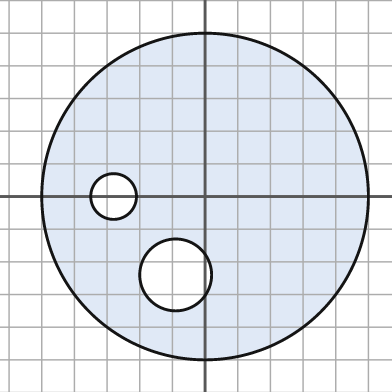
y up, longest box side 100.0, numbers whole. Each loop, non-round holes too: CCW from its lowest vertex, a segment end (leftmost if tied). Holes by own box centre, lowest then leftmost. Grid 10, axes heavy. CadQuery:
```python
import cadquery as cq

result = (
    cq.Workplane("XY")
    .moveTo(0.0, 0.0)
    .circle(50.0)
    .moveTo(-9.0, -24.0)
    .circle(11.0)
    .moveTo(-28.0, 0.0)
    .circle(7.0)
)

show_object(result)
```